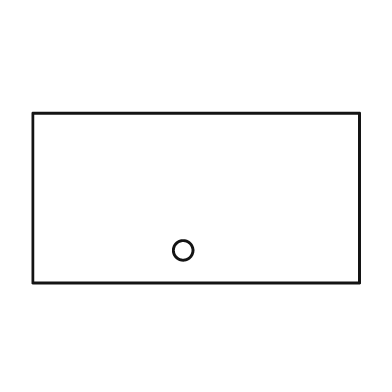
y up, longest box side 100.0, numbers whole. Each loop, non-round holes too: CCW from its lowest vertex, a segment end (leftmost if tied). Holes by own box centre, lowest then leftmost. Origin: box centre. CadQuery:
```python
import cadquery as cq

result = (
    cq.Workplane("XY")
    .moveTo(-50.0, -26.0)
    .lineTo(50.0, -26.0)
    .lineTo(50.0, 26.0)
    .lineTo(-50.0, 26.0)
    .close()
    .moveTo(-4.0, -16.0)
    .circle(3.0)
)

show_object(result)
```